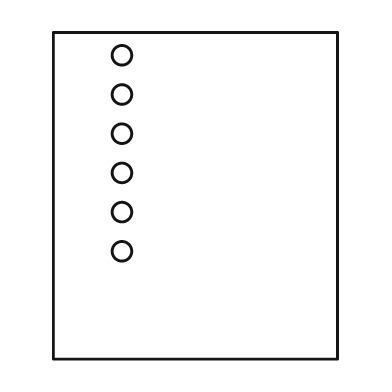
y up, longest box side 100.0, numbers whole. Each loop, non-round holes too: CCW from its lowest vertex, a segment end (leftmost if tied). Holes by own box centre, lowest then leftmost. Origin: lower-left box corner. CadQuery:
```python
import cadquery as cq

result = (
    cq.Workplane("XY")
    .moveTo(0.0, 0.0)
    .lineTo(87.0, 0.0)
    .lineTo(87.0, 100.0)
    .lineTo(0.0, 100.0)
    .close()
    .moveTo(21.0, 33.0)
    .circle(3.0)
    .moveTo(21.0, 45.0)
    .circle(3.0)
    .moveTo(21.0, 57.0)
    .circle(3.0)
    .moveTo(21.0, 69.0)
    .circle(3.0)
    .moveTo(21.0, 81.0)
    .circle(3.0)
    .moveTo(21.0, 93.0)
    .circle(3.0)
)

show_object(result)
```